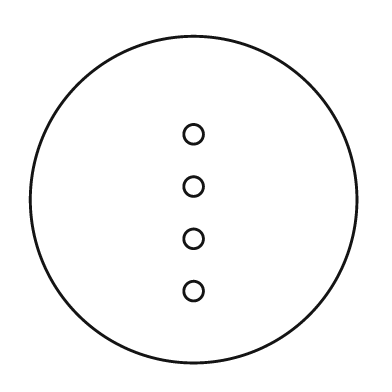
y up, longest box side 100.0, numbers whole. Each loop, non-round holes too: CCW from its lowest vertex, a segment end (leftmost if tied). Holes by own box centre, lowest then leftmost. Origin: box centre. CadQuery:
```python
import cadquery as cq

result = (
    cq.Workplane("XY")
    .moveTo(0.0, 0.0)
    .circle(50.0)
    .moveTo(0.0, -28.0)
    .circle(3.0)
    .moveTo(0.0, -12.0)
    .circle(3.0)
    .moveTo(0.0, 4.0)
    .circle(3.0)
    .moveTo(0.0, 20.0)
    .circle(3.0)
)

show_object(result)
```